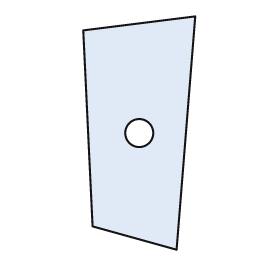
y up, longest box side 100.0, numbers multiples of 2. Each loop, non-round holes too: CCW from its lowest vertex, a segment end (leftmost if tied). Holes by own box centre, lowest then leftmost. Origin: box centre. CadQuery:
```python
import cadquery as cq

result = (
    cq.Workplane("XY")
    .moveTo(16.0, -50.0)
    .lineTo(24.0, 50.0)
    .lineTo(-24.0, 44.0)
    .lineTo(-20.0, -40.0)
    .close()
    .moveTo(0.0, 0.0)
    .circle(6.0)
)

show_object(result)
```